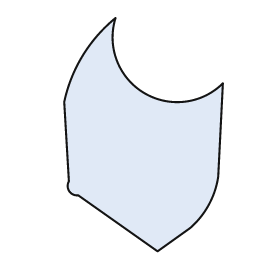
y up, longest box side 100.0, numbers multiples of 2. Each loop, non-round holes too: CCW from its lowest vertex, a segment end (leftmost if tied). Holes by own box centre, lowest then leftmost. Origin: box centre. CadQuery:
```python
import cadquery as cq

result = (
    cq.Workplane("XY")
    .moveTo(6.0, -50.0)
    .lineTo(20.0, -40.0)
    .threePointArc((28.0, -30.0), (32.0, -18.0))
    .lineTo(34.0, 22.0)
    .threePointArc((0.0, 18.0), (-12.0, 50.0))
    .threePointArc((-26.0, 34.0), (-34.0, 14.0))
    .lineTo(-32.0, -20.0)
    .threePointArc((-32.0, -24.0), (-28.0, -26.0))
    .close()
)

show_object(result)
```